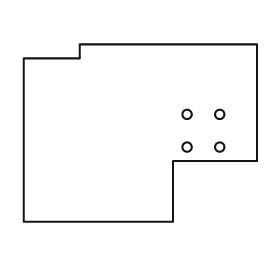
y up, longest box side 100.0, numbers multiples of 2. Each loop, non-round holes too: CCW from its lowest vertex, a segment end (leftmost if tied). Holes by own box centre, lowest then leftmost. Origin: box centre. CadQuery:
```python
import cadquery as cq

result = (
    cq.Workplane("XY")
    .moveTo(-50.0, -38.0)
    .lineTo(14.0, -38.0)
    .lineTo(14.0, -12.0)
    .lineTo(50.0, -12.0)
    .lineTo(50.0, 38.0)
    .lineTo(-26.0, 38.0)
    .lineTo(-26.0, 32.0)
    .lineTo(-50.0, 32.0)
    .close()
    .moveTo(20.0, -6.0)
    .circle(2.0)
    .moveTo(34.0, -6.0)
    .circle(2.0)
    .moveTo(20.0, 8.0)
    .circle(2.0)
    .moveTo(34.0, 8.0)
    .circle(2.0)
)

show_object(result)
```